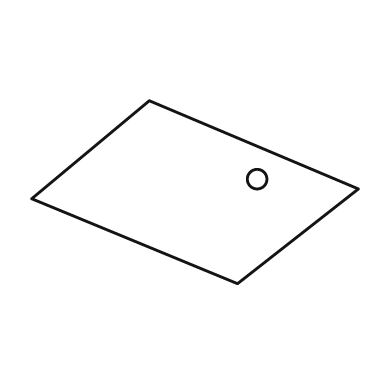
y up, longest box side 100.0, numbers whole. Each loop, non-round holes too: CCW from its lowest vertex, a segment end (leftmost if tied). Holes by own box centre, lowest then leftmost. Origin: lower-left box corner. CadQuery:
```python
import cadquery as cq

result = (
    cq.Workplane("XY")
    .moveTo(63.0, 0.0)
    .lineTo(100.0, 29.0)
    .lineTo(36.0, 56.0)
    .lineTo(0.0, 26.0)
    .close()
    .moveTo(69.0, 32.0)
    .circle(3.0)
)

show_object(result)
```